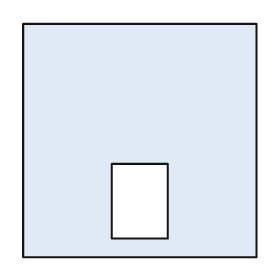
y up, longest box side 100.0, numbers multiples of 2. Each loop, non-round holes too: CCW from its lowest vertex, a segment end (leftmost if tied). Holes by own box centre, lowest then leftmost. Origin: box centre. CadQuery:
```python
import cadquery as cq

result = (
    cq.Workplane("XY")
    .moveTo(-50.0, -50.0)
    .lineTo(50.0, -50.0)
    .lineTo(50.0, 50.0)
    .lineTo(-50.0, 50.0)
    .close()
    .moveTo(-12.0, -42.0)
    .lineTo(12.0, -42.0)
    .lineTo(12.0, -10.0)
    .lineTo(-12.0, -10.0)
    .close()
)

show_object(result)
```